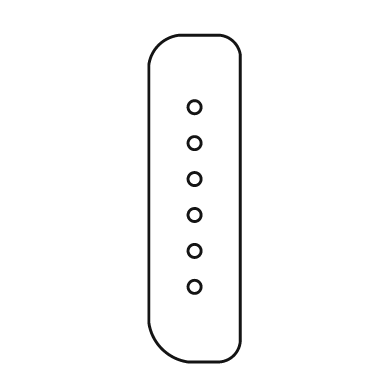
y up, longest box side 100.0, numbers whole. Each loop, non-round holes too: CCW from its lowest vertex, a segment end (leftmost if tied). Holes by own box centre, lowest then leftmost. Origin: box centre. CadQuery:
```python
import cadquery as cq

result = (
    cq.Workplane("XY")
    .moveTo(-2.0, -50.0)
    .lineTo(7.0, -50.0)
    .threePointArc((12.0, -48.0), (14.0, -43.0))
    .lineTo(14.0, 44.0)
    .threePointArc((12.0, 48.0), (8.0, 50.0))
    .lineTo(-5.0, 50.0)
    .threePointArc((-11.0, 47.0), (-14.0, 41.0))
    .lineTo(-14.0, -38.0)
    .threePointArc((-10.0, -46.0), (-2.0, -50.0))
    .close()
    .moveTo(0.0, -27.0)
    .circle(2.0)
    .moveTo(0.0, -16.0)
    .circle(2.0)
    .moveTo(0.0, -5.0)
    .circle(2.0)
    .moveTo(0.0, 6.0)
    .circle(2.0)
    .moveTo(0.0, 17.0)
    .circle(2.0)
    .moveTo(0.0, 28.0)
    .circle(2.0)
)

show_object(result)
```